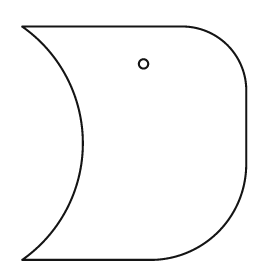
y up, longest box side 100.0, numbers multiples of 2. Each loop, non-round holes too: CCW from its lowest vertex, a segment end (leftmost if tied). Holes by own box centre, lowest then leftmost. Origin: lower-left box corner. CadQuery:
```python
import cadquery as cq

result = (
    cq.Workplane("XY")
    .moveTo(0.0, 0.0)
    .lineTo(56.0, 0.0)
    .threePointArc((84.0, 12.0), (96.0, 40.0))
    .lineTo(96.0, 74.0)
    .threePointArc((88.0, 92.0), (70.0, 100.0))
    .lineTo(0.0, 100.0)
    .threePointArc((26.0, 50.0), (0.0, 0.0))
    .close()
    .moveTo(52.0, 84.0)
    .circle(2.0)
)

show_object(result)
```